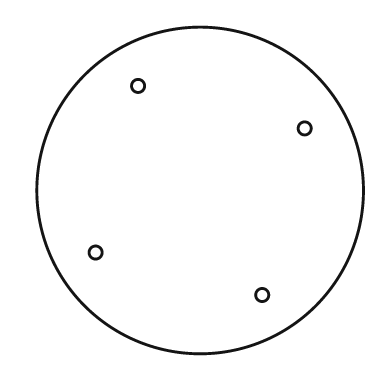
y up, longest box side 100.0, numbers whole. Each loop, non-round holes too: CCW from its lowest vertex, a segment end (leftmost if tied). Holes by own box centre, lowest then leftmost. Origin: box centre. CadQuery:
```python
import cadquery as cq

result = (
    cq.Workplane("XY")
    .moveTo(0.0, 0.0)
    .circle(50.0)
    .moveTo(19.0, -32.0)
    .circle(2.0)
    .moveTo(-32.0, -19.0)
    .circle(2.0)
    .moveTo(32.0, 19.0)
    .circle(2.0)
    .moveTo(-19.0, 32.0)
    .circle(2.0)
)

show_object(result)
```